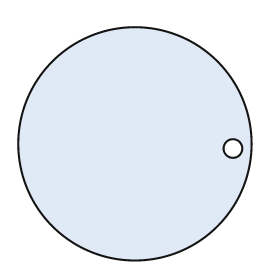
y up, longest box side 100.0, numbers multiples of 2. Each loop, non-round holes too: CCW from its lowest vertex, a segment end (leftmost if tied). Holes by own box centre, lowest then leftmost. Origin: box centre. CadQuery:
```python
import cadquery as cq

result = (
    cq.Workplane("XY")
    .moveTo(0.0, 0.0)
    .circle(50.0)
    .moveTo(42.0, -2.0)
    .circle(4.0)
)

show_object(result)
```